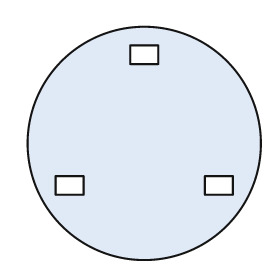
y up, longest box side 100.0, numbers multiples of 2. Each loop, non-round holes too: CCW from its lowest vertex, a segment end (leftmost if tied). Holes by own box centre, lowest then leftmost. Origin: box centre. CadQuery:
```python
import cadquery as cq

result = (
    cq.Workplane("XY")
    .moveTo(0.0, 0.0)
    .circle(50.0)
    .moveTo(-38.0, -22.0)
    .lineTo(-26.0, -22.0)
    .lineTo(-26.0, -14.0)
    .lineTo(-38.0, -14.0)
    .close()
    .moveTo(26.0, -22.0)
    .lineTo(38.0, -22.0)
    .lineTo(38.0, -14.0)
    .lineTo(26.0, -14.0)
    .close()
    .moveTo(-6.0, 34.0)
    .lineTo(6.0, 34.0)
    .lineTo(6.0, 42.0)
    .lineTo(-6.0, 42.0)
    .close()
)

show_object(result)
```